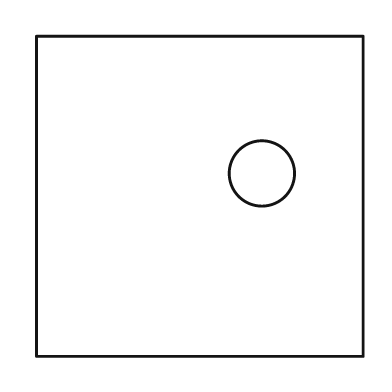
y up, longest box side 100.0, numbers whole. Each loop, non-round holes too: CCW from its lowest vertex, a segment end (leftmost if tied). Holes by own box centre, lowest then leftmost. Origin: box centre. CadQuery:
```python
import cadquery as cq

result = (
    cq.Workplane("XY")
    .moveTo(-50.0, -49.0)
    .lineTo(50.0, -49.0)
    .lineTo(50.0, 49.0)
    .lineTo(-50.0, 49.0)
    .close()
    .moveTo(19.0, 7.0)
    .circle(10.0)
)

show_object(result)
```